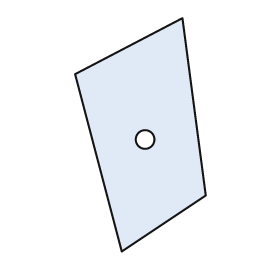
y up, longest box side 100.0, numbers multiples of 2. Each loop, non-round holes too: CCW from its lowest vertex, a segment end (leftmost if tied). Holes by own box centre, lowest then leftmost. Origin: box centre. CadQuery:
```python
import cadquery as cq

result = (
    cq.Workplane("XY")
    .moveTo(-8.0, -50.0)
    .lineTo(28.0, -26.0)
    .lineTo(18.0, 50.0)
    .lineTo(-28.0, 26.0)
    .close()
    .moveTo(2.0, -2.0)
    .circle(4.0)
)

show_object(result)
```